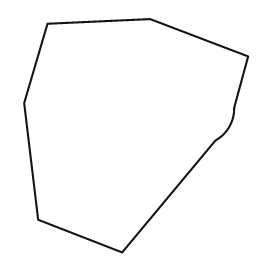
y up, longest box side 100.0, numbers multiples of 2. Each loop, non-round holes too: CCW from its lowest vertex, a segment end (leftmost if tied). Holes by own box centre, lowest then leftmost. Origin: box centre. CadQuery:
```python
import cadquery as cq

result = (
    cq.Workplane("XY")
    .moveTo(-6.0, -50.0)
    .lineTo(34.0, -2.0)
    .threePointArc((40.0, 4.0), (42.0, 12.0))
    .lineTo(48.0, 34.0)
    .lineTo(6.0, 50.0)
    .lineTo(-38.0, 48.0)
    .lineTo(-48.0, 14.0)
    .lineTo(-42.0, -36.0)
    .close()
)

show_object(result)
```